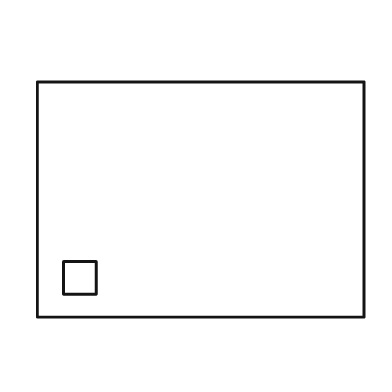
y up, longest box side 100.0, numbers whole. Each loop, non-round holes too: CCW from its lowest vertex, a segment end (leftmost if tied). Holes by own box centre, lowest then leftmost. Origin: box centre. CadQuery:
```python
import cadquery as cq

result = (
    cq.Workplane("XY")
    .moveTo(-50.0, -36.0)
    .lineTo(50.0, -36.0)
    .lineTo(50.0, 36.0)
    .lineTo(-50.0, 36.0)
    .close()
    .moveTo(-42.0, -29.0)
    .lineTo(-32.0, -29.0)
    .lineTo(-32.0, -19.0)
    .lineTo(-42.0, -19.0)
    .close()
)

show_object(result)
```